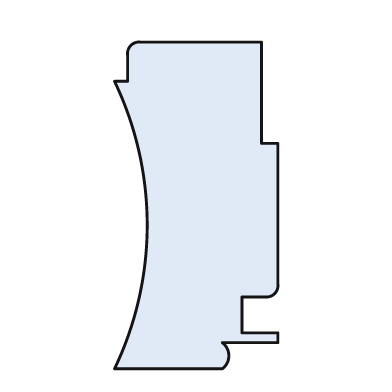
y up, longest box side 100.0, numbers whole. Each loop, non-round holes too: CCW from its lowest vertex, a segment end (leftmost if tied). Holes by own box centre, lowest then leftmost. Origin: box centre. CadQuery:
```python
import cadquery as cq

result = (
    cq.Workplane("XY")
    .moveTo(-25.0, -50.0)
    .lineTo(8.0, -50.0)
    .threePointArc((10.0, -46.0), (8.0, -42.0))
    .lineTo(25.0, -42.0)
    .lineTo(25.0, -39.0)
    .lineTo(14.0, -39.0)
    .lineTo(14.0, -28.0)
    .lineTo(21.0, -28.0)
    .threePointArc((24.0, -27.0), (25.0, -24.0))
    .lineTo(25.0, 19.0)
    .lineTo(20.0, 19.0)
    .lineTo(20.0, 50.0)
    .lineTo(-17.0, 50.0)
    .threePointArc((-20.0, 49.0), (-21.0, 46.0))
    .lineTo(-21.0, 38.0)
    .lineTo(-25.0, 38.0)
    .threePointArc((-15.0, -6.0), (-25.0, -50.0))
    .close()
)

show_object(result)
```